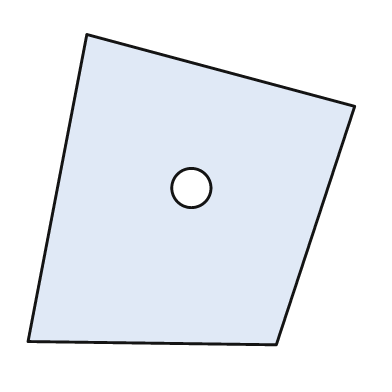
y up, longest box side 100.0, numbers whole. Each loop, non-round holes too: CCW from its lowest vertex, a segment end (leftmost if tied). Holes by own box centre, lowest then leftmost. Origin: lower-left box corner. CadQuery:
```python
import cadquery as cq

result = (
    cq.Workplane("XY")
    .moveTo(76.0, 0.0)
    .lineTo(100.0, 73.0)
    .lineTo(18.0, 95.0)
    .lineTo(0.0, 1.0)
    .close()
    .moveTo(50.0, 48.0)
    .circle(6.0)
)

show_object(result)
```